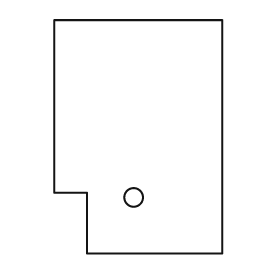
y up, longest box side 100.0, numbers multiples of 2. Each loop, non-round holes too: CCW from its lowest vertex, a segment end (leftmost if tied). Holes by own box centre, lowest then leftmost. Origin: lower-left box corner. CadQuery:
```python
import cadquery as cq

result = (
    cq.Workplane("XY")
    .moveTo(14.0, 0.0)
    .lineTo(72.0, 0.0)
    .lineTo(72.0, 100.0)
    .lineTo(0.0, 100.0)
    .lineTo(0.0, 26.0)
    .lineTo(14.0, 26.0)
    .close()
    .moveTo(34.0, 24.0)
    .circle(4.0)
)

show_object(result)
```